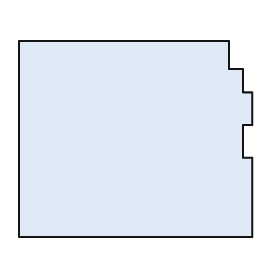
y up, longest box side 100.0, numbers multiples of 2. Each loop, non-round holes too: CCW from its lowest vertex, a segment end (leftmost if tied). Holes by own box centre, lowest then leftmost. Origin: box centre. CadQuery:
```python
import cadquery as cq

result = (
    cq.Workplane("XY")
    .moveTo(-50.0, -42.0)
    .lineTo(50.0, -42.0)
    .lineTo(50.0, -8.0)
    .lineTo(46.0, -8.0)
    .lineTo(46.0, 6.0)
    .lineTo(50.0, 6.0)
    .lineTo(50.0, 20.0)
    .lineTo(46.0, 20.0)
    .lineTo(46.0, 30.0)
    .lineTo(40.0, 30.0)
    .lineTo(40.0, 42.0)
    .lineTo(-50.0, 42.0)
    .close()
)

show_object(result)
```